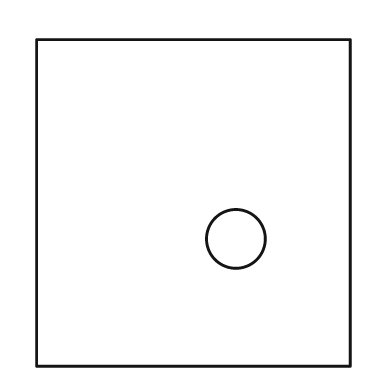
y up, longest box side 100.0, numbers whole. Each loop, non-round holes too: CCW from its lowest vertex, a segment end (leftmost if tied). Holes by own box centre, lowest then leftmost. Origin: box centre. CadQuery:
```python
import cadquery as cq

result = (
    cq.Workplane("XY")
    .moveTo(-48.0, -50.0)
    .lineTo(48.0, -50.0)
    .lineTo(48.0, 50.0)
    .lineTo(-48.0, 50.0)
    .close()
    .moveTo(13.0, -11.0)
    .circle(9.0)
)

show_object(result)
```